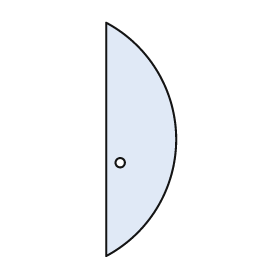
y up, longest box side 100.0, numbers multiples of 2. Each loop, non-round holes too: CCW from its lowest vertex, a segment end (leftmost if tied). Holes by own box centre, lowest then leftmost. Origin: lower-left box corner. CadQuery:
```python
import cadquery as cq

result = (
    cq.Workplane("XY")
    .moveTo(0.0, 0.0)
    .threePointArc((30.0, 50.0), (0.0, 100.0))
    .close()
    .moveTo(6.0, 40.0)
    .circle(2.0)
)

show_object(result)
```